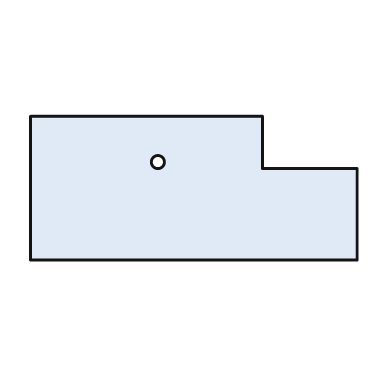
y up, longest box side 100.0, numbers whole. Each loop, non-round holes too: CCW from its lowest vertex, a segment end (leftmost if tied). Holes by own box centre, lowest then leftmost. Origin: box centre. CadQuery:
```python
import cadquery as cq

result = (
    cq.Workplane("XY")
    .moveTo(-50.0, -22.0)
    .lineTo(50.0, -22.0)
    .lineTo(50.0, 6.0)
    .lineTo(21.0, 6.0)
    .lineTo(21.0, 22.0)
    .lineTo(-50.0, 22.0)
    .close()
    .moveTo(-11.0, 8.0)
    .circle(2.0)
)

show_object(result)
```